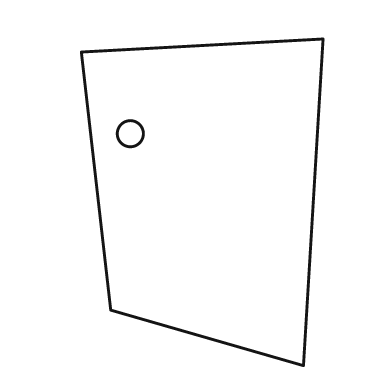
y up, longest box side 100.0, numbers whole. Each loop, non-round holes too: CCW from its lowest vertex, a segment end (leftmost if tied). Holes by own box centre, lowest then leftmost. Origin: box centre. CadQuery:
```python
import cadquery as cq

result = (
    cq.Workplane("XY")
    .moveTo(31.0, -50.0)
    .lineTo(37.0, 50.0)
    .lineTo(-37.0, 46.0)
    .lineTo(-28.0, -33.0)
    .close()
    .moveTo(-22.0, 21.0)
    .circle(4.0)
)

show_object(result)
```